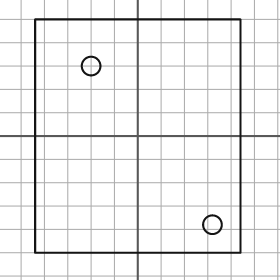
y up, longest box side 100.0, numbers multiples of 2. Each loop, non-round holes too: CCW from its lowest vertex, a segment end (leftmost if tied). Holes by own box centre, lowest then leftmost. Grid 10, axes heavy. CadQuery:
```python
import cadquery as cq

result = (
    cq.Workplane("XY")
    .moveTo(-44.0, -50.0)
    .lineTo(44.0, -50.0)
    .lineTo(44.0, 50.0)
    .lineTo(-44.0, 50.0)
    .close()
    .moveTo(32.0, -38.0)
    .circle(4.0)
    .moveTo(-20.0, 30.0)
    .circle(4.0)
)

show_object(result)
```